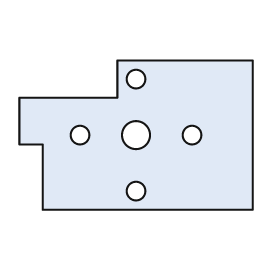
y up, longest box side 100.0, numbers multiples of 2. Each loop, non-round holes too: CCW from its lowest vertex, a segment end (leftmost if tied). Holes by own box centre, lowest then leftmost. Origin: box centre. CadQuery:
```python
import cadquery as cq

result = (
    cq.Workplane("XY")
    .moveTo(-40.0, -32.0)
    .lineTo(50.0, -32.0)
    .lineTo(50.0, 32.0)
    .lineTo(-8.0, 32.0)
    .lineTo(-8.0, 16.0)
    .lineTo(-50.0, 16.0)
    .lineTo(-50.0, -4.0)
    .lineTo(-40.0, -4.0)
    .close()
    .moveTo(0.0, -24.0)
    .circle(4.0)
    .moveTo(-24.0, 0.0)
    .circle(4.0)
    .moveTo(0.0, 0.0)
    .circle(6.0)
    .moveTo(24.0, 0.0)
    .circle(4.0)
    .moveTo(0.0, 24.0)
    .circle(4.0)
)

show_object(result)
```